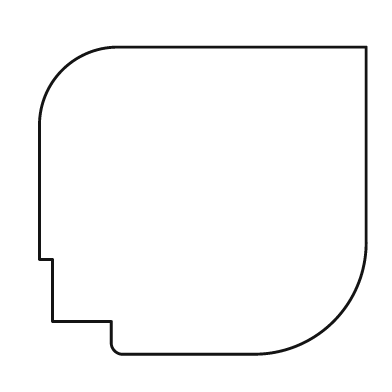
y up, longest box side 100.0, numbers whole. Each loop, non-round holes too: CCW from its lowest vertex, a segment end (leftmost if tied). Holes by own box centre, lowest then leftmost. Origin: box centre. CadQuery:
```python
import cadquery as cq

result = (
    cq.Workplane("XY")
    .moveTo(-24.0, -47.0)
    .lineTo(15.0, -47.0)
    .threePointArc((40.0, -37.0), (50.0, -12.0))
    .lineTo(50.0, 47.0)
    .lineTo(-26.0, 47.0)
    .threePointArc((-43.0, 40.0), (-50.0, 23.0))
    .lineTo(-50.0, -18.0)
    .lineTo(-46.0, -18.0)
    .lineTo(-46.0, -37.0)
    .lineTo(-28.0, -37.0)
    .lineTo(-28.0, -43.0)
    .threePointArc((-27.0, -46.0), (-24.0, -47.0))
    .close()
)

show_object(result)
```